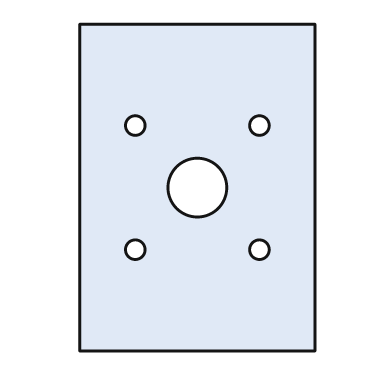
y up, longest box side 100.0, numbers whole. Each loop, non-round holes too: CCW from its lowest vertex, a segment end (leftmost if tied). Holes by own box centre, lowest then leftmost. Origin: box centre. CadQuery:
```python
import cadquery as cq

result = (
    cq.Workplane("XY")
    .moveTo(-36.0, -50.0)
    .lineTo(36.0, -50.0)
    .lineTo(36.0, 50.0)
    .lineTo(-36.0, 50.0)
    .close()
    .moveTo(-19.0, -19.0)
    .circle(3.0)
    .moveTo(19.0, -19.0)
    .circle(3.0)
    .moveTo(0.0, 0.0)
    .circle(9.0)
    .moveTo(-19.0, 19.0)
    .circle(3.0)
    .moveTo(19.0, 19.0)
    .circle(3.0)
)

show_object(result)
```